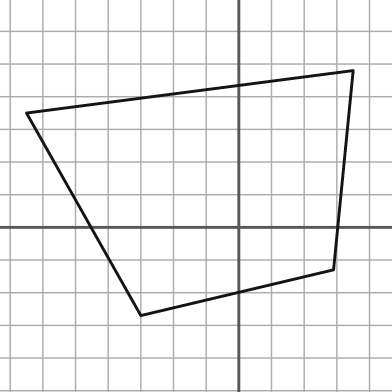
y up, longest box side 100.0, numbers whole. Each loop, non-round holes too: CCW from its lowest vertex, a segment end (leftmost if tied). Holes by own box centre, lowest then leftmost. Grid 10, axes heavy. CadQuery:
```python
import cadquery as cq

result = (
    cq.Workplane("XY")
    .moveTo(-30.0, -27.0)
    .lineTo(29.0, -13.0)
    .lineTo(35.0, 48.0)
    .lineTo(-65.0, 35.0)
    .close()
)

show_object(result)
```